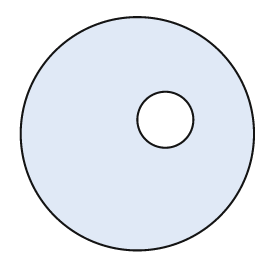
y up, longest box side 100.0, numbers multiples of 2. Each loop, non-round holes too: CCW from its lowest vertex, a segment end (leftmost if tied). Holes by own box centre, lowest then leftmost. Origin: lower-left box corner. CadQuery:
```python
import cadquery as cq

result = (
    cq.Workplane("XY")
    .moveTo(50.0, 50.0)
    .circle(50.0)
    .moveTo(62.0, 56.0)
    .circle(12.0)
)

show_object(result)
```